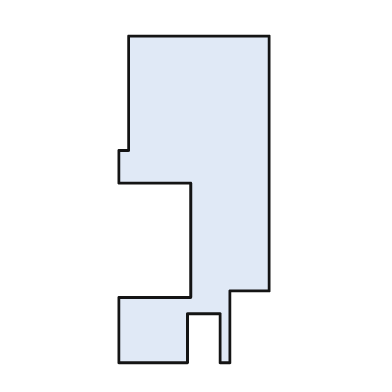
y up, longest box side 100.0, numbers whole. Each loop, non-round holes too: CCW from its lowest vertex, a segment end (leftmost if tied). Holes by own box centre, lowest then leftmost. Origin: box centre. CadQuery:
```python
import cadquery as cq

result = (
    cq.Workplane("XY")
    .moveTo(-23.0, -50.0)
    .lineTo(-2.0, -50.0)
    .lineTo(-2.0, -35.0)
    .lineTo(8.0, -35.0)
    .lineTo(8.0, -50.0)
    .lineTo(11.0, -50.0)
    .lineTo(11.0, -28.0)
    .lineTo(23.0, -28.0)
    .lineTo(23.0, 50.0)
    .lineTo(-20.0, 50.0)
    .lineTo(-20.0, 15.0)
    .lineTo(-23.0, 15.0)
    .lineTo(-23.0, 5.0)
    .lineTo(-1.0, 5.0)
    .lineTo(-1.0, -30.0)
    .lineTo(-23.0, -30.0)
    .close()
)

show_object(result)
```